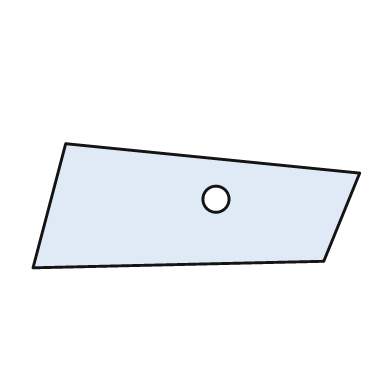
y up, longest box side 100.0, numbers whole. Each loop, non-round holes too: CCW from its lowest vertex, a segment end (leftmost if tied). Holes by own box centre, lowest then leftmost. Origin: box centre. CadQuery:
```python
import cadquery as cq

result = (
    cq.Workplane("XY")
    .moveTo(-50.0, -19.0)
    .lineTo(39.0, -17.0)
    .lineTo(50.0, 10.0)
    .lineTo(-40.0, 19.0)
    .close()
    .moveTo(6.0, 2.0)
    .circle(4.0)
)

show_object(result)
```